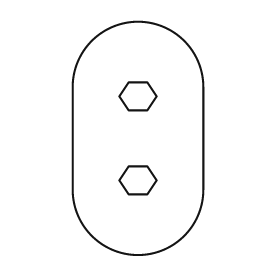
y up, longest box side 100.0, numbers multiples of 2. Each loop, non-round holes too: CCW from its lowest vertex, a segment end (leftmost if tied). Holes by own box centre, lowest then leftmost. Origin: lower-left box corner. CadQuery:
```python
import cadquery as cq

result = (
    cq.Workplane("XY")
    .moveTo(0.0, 28.0)
    .threePointArc((28.0, 0.0), (56.0, 28.0))
    .lineTo(56.0, 72.0)
    .threePointArc((28.0, 100.0), (0.0, 72.0))
    .close()
    .moveTo(24.0, 26.0)
    .lineTo(32.0, 26.0)
    .lineTo(36.0, 32.0)
    .lineTo(32.0, 38.0)
    .lineTo(24.0, 38.0)
    .lineTo(20.0, 32.0)
    .close()
    .moveTo(24.0, 62.0)
    .lineTo(32.0, 62.0)
    .lineTo(36.0, 68.0)
    .lineTo(32.0, 74.0)
    .lineTo(24.0, 74.0)
    .lineTo(20.0, 68.0)
    .close()
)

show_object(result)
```